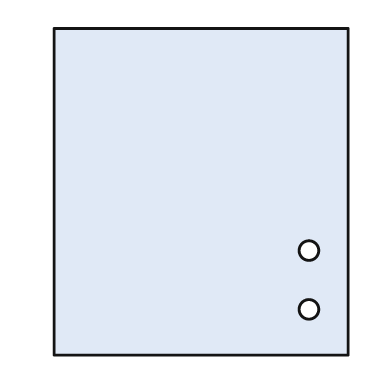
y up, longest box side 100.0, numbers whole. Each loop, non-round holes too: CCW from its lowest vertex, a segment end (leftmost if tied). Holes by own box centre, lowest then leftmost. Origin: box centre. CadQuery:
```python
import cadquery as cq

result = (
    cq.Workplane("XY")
    .moveTo(-45.0, -50.0)
    .lineTo(45.0, -50.0)
    .lineTo(45.0, 50.0)
    .lineTo(-45.0, 50.0)
    .close()
    .moveTo(33.0, -36.0)
    .circle(3.0)
    .moveTo(33.0, -18.0)
    .circle(3.0)
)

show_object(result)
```